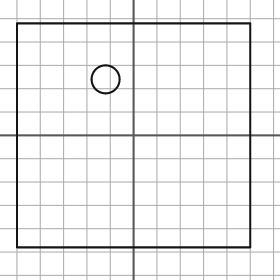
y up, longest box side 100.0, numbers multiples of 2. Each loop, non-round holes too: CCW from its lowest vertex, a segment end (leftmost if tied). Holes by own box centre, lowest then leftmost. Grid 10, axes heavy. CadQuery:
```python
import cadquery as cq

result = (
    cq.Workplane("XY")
    .moveTo(-50.0, -48.0)
    .lineTo(50.0, -48.0)
    .lineTo(50.0, 48.0)
    .lineTo(-50.0, 48.0)
    .close()
    .moveTo(-12.0, 24.0)
    .circle(6.0)
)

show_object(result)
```